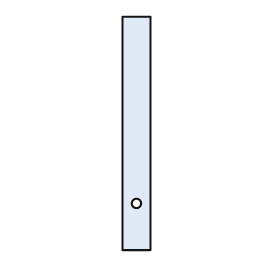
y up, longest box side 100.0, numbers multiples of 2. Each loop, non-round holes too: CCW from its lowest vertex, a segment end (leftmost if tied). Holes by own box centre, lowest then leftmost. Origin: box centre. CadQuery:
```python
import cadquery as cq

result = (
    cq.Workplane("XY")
    .moveTo(-6.0, -50.0)
    .lineTo(6.0, -50.0)
    .lineTo(6.0, 50.0)
    .lineTo(-6.0, 50.0)
    .close()
    .moveTo(0.0, -30.0)
    .circle(2.0)
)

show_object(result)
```